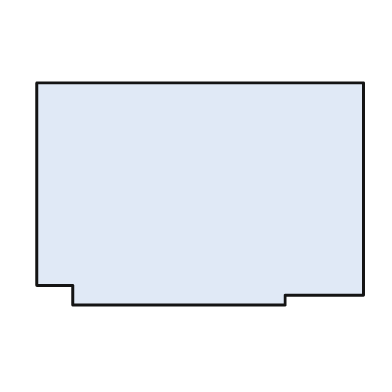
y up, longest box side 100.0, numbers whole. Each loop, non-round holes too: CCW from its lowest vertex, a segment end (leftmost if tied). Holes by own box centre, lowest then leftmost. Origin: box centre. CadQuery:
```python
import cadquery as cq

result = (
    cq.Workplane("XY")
    .moveTo(-39.0, -34.0)
    .lineTo(26.0, -34.0)
    .lineTo(26.0, -31.0)
    .lineTo(50.0, -31.0)
    .lineTo(50.0, 34.0)
    .lineTo(-50.0, 34.0)
    .lineTo(-50.0, -28.0)
    .lineTo(-39.0, -28.0)
    .close()
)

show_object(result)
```